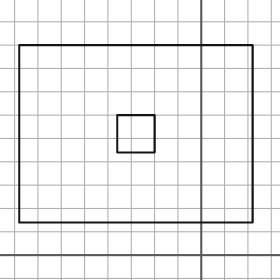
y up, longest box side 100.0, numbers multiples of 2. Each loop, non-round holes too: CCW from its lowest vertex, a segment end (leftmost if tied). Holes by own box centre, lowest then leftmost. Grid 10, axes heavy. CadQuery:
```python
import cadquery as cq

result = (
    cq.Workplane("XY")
    .moveTo(-78.0, 14.0)
    .lineTo(22.0, 14.0)
    .lineTo(22.0, 90.0)
    .lineTo(-78.0, 90.0)
    .close()
    .moveTo(-36.0, 44.0)
    .lineTo(-20.0, 44.0)
    .lineTo(-20.0, 60.0)
    .lineTo(-36.0, 60.0)
    .close()
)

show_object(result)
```